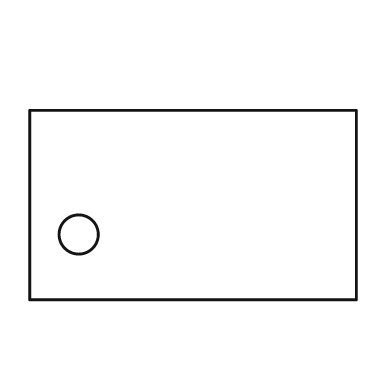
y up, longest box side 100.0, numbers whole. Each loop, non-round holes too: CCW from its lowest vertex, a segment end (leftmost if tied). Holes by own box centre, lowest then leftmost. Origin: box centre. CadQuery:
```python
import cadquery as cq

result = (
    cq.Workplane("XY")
    .moveTo(-50.0, -29.0)
    .lineTo(50.0, -29.0)
    .lineTo(50.0, 29.0)
    .lineTo(-50.0, 29.0)
    .close()
    .moveTo(-35.0, -9.0)
    .circle(6.0)
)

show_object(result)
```